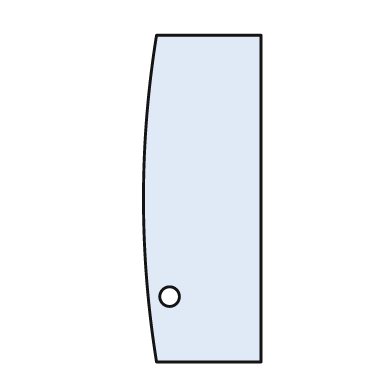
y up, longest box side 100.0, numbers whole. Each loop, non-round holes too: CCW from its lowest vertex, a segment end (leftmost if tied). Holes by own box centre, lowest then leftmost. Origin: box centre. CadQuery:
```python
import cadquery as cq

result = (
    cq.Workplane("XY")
    .moveTo(-14.0, -50.0)
    .lineTo(18.0, -50.0)
    .lineTo(18.0, 50.0)
    .lineTo(-14.0, 50.0)
    .threePointArc((-18.0, 0.0), (-14.0, -50.0))
    .close()
    .moveTo(-10.0, -30.0)
    .circle(3.0)
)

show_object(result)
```